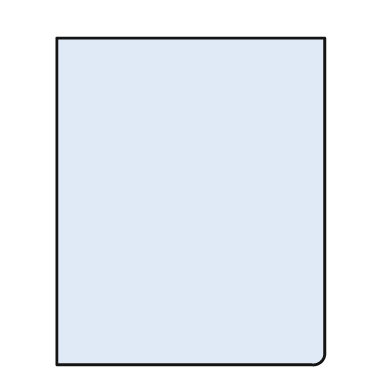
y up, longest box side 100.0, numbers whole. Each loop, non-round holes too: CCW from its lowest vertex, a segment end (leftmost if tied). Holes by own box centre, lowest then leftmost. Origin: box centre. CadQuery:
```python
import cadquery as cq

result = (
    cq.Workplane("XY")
    .moveTo(-41.0, -50.0)
    .lineTo(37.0, -50.0)
    .threePointArc((40.0, -49.0), (41.0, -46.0))
    .lineTo(41.0, 50.0)
    .lineTo(-41.0, 50.0)
    .close()
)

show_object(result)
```